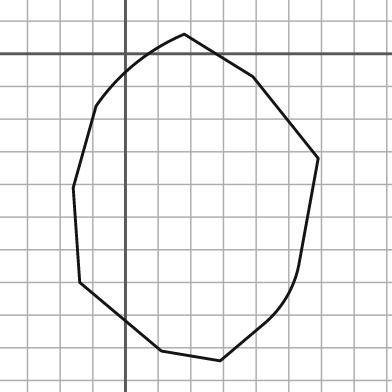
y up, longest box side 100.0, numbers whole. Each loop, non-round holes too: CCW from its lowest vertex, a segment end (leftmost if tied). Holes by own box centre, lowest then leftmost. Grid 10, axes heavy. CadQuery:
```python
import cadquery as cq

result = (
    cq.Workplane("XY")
    .moveTo(29.0, -94.0)
    .lineTo(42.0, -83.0)
    .threePointArc((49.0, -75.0), (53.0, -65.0))
    .lineTo(59.0, -32.0)
    .lineTo(39.0, -7.0)
    .lineTo(18.0, 6.0)
    .threePointArc((3.0, -3.0), (-9.0, -16.0))
    .lineTo(-16.0, -41.0)
    .lineTo(-14.0, -70.0)
    .lineTo(11.0, -91.0)
    .close()
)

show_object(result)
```